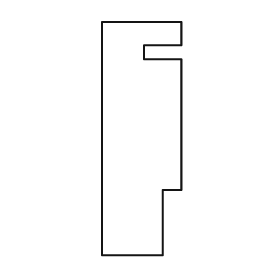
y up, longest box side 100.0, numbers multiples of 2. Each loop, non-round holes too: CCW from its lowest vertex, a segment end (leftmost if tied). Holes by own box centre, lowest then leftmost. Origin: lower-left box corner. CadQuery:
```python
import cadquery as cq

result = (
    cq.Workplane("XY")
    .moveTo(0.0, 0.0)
    .lineTo(26.0, 0.0)
    .lineTo(26.0, 28.0)
    .lineTo(34.0, 28.0)
    .lineTo(34.0, 84.0)
    .lineTo(18.0, 84.0)
    .lineTo(18.0, 90.0)
    .lineTo(34.0, 90.0)
    .lineTo(34.0, 100.0)
    .lineTo(0.0, 100.0)
    .close()
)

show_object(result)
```